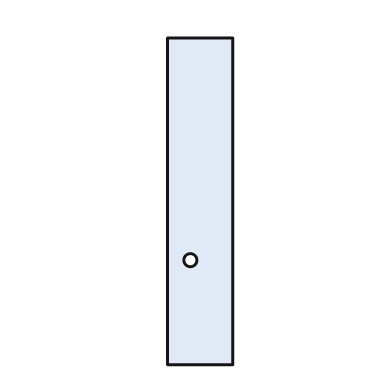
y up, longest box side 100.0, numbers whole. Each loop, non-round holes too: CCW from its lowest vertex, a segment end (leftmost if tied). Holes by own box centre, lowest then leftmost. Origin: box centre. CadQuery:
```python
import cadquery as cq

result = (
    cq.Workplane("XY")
    .moveTo(-10.0, -50.0)
    .lineTo(10.0, -50.0)
    .lineTo(10.0, 50.0)
    .lineTo(-10.0, 50.0)
    .close()
    .moveTo(-3.0, -18.0)
    .circle(2.0)
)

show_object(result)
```